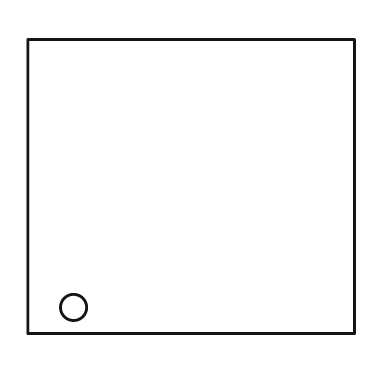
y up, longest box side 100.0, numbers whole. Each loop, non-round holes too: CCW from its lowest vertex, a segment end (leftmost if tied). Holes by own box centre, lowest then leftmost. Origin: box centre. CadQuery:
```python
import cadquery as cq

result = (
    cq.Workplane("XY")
    .moveTo(-50.0, -45.0)
    .lineTo(50.0, -45.0)
    .lineTo(50.0, 45.0)
    .lineTo(-50.0, 45.0)
    .close()
    .moveTo(-36.0, -37.0)
    .circle(4.0)
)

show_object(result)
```